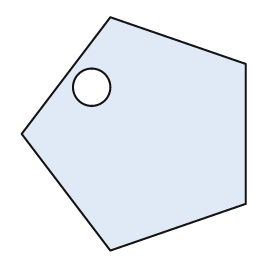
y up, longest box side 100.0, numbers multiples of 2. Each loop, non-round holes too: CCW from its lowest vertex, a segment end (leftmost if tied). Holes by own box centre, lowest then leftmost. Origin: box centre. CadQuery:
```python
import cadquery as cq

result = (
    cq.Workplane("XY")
    .moveTo(-10.0, -50.0)
    .lineTo(48.0, -30.0)
    .lineTo(48.0, 30.0)
    .lineTo(-10.0, 50.0)
    .lineTo(-48.0, 0.0)
    .close()
    .moveTo(-18.0, 20.0)
    .circle(8.0)
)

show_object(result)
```